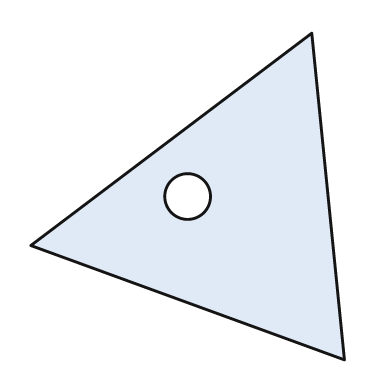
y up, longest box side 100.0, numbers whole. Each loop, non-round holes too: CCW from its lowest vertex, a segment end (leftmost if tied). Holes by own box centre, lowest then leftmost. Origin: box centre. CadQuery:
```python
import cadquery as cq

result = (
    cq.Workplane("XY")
    .moveTo(48.0, -50.0)
    .lineTo(38.0, 50.0)
    .lineTo(-48.0, -15.0)
    .close()
    .moveTo(0.0, 0.0)
    .circle(7.0)
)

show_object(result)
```